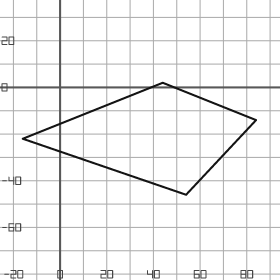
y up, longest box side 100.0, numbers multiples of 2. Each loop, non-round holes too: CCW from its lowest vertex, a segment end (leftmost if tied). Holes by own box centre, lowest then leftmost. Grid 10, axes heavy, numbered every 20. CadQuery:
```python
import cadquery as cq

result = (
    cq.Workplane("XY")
    .moveTo(54.0, -46.0)
    .lineTo(84.0, -14.0)
    .lineTo(44.0, 2.0)
    .lineTo(-16.0, -22.0)
    .close()
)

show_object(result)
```